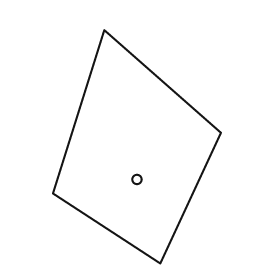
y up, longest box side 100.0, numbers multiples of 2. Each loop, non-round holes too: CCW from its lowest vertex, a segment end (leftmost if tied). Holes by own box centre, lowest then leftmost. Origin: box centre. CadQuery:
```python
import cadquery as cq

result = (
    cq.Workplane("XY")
    .moveTo(10.0, -50.0)
    .lineTo(36.0, 6.0)
    .lineTo(-14.0, 50.0)
    .lineTo(-36.0, -20.0)
    .close()
    .moveTo(0.0, -14.0)
    .circle(2.0)
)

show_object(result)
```